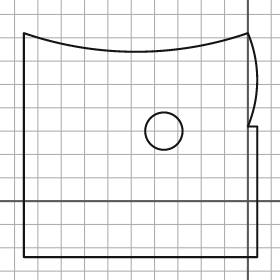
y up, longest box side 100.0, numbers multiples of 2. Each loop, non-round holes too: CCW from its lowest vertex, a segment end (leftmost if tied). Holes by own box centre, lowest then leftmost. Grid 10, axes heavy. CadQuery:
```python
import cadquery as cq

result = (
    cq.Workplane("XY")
    .moveTo(-96.0, -24.0)
    .lineTo(4.0, -24.0)
    .lineTo(4.0, 32.0)
    .lineTo(0.0, 32.0)
    .threePointArc((4.0, 52.0), (0.0, 72.0))
    .threePointArc((-48.0, 64.0), (-96.0, 72.0))
    .close()
    .moveTo(-36.0, 30.0)
    .circle(8.0)
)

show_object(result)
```